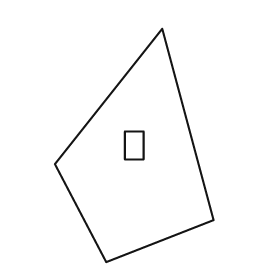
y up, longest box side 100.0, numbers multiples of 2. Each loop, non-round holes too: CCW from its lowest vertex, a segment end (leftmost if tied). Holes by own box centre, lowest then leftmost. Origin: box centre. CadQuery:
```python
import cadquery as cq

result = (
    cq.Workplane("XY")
    .moveTo(-12.0, -50.0)
    .lineTo(34.0, -32.0)
    .lineTo(12.0, 50.0)
    .lineTo(-34.0, -8.0)
    .close()
    .moveTo(-4.0, -6.0)
    .lineTo(4.0, -6.0)
    .lineTo(4.0, 6.0)
    .lineTo(-4.0, 6.0)
    .close()
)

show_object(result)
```